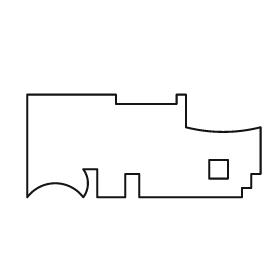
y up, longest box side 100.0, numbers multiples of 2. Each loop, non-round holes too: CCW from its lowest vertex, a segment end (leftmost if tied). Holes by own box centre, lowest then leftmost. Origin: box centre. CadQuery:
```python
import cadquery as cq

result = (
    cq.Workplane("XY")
    .moveTo(-50.0, -22.0)
    .threePointArc((-38.0, -16.0), (-26.0, -22.0))
    .threePointArc((-24.0, -16.0), (-26.0, -10.0))
    .lineTo(-20.0, -10.0)
    .lineTo(-20.0, -22.0)
    .lineTo(-8.0, -22.0)
    .lineTo(-8.0, -12.0)
    .lineTo(-2.0, -12.0)
    .lineTo(-2.0, -22.0)
    .lineTo(42.0, -22.0)
    .lineTo(42.0, -18.0)
    .lineTo(46.0, -18.0)
    .lineTo(46.0, -12.0)
    .lineTo(50.0, -12.0)
    .lineTo(50.0, 8.0)
    .threePointArc((34.0, 6.0), (18.0, 8.0))
    .lineTo(18.0, 22.0)
    .lineTo(14.0, 22.0)
    .lineTo(14.0, 18.0)
    .lineTo(-12.0, 18.0)
    .lineTo(-12.0, 22.0)
    .lineTo(-50.0, 22.0)
    .close()
    .moveTo(28.0, -14.0)
    .lineTo(36.0, -14.0)
    .lineTo(36.0, -6.0)
    .lineTo(28.0, -6.0)
    .close()
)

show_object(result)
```